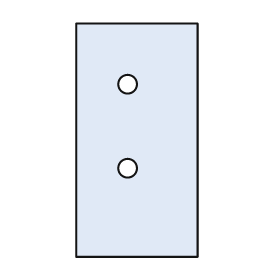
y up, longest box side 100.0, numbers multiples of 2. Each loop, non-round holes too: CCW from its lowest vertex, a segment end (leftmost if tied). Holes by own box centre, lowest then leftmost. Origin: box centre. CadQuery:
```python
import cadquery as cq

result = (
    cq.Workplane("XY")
    .moveTo(-26.0, -50.0)
    .lineTo(26.0, -50.0)
    .lineTo(26.0, 50.0)
    .lineTo(-26.0, 50.0)
    .close()
    .moveTo(-4.0, -12.0)
    .circle(4.0)
    .moveTo(-4.0, 24.0)
    .circle(4.0)
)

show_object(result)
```